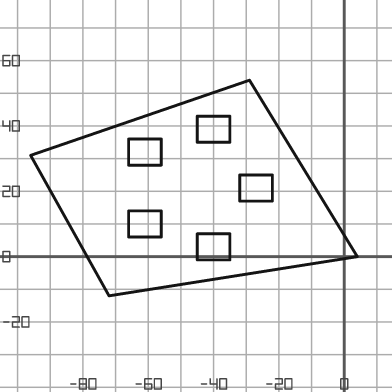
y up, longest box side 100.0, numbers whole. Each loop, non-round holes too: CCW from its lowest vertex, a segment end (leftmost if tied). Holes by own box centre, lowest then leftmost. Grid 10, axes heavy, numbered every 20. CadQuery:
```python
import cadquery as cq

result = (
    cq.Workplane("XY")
    .moveTo(-72.0, -12.0)
    .lineTo(4.0, 0.0)
    .lineTo(-29.0, 54.0)
    .lineTo(-96.0, 31.0)
    .close()
    .moveTo(-45.0, -1.0)
    .lineTo(-35.0, -1.0)
    .lineTo(-35.0, 7.0)
    .lineTo(-45.0, 7.0)
    .close()
    .moveTo(-66.0, 6.0)
    .lineTo(-56.0, 6.0)
    .lineTo(-56.0, 14.0)
    .lineTo(-66.0, 14.0)
    .close()
    .moveTo(-32.0, 17.0)
    .lineTo(-22.0, 17.0)
    .lineTo(-22.0, 25.0)
    .lineTo(-32.0, 25.0)
    .close()
    .moveTo(-66.0, 28.0)
    .lineTo(-56.0, 28.0)
    .lineTo(-56.0, 36.0)
    .lineTo(-66.0, 36.0)
    .close()
    .moveTo(-45.0, 35.0)
    .lineTo(-35.0, 35.0)
    .lineTo(-35.0, 43.0)
    .lineTo(-45.0, 43.0)
    .close()
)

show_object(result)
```